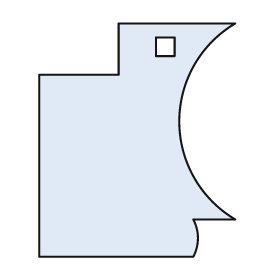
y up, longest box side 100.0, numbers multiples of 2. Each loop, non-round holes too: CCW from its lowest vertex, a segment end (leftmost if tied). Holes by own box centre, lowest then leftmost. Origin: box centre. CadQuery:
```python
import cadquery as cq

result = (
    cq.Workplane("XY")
    .moveTo(-42.0, -50.0)
    .lineTo(24.0, -50.0)
    .threePointArc((26.0, -42.0), (24.0, -34.0))
    .lineTo(42.0, -34.0)
    .threePointArc((18.0, 8.0), (42.0, 50.0))
    .lineTo(-8.0, 50.0)
    .lineTo(-8.0, 28.0)
    .lineTo(-42.0, 28.0)
    .close()
    .moveTo(8.0, 36.0)
    .lineTo(16.0, 36.0)
    .lineTo(16.0, 44.0)
    .lineTo(8.0, 44.0)
    .close()
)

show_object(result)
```